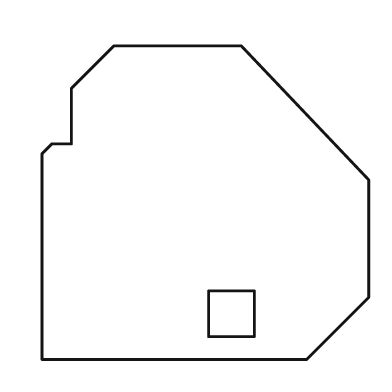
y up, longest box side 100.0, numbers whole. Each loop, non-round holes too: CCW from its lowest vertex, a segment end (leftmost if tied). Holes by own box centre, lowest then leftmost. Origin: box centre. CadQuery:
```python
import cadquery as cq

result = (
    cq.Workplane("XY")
    .moveTo(-50.0, -48.0)
    .lineTo(31.0, -48.0)
    .lineTo(50.0, -29.0)
    .lineTo(50.0, 7.0)
    .lineTo(11.0, 48.0)
    .lineTo(-28.0, 48.0)
    .lineTo(-41.0, 35.0)
    .lineTo(-41.0, 18.0)
    .lineTo(-47.0, 18.0)
    .lineTo(-50.0, 15.0)
    .close()
    .moveTo(1.0, -41.0)
    .lineTo(15.0, -41.0)
    .lineTo(15.0, -27.0)
    .lineTo(1.0, -27.0)
    .close()
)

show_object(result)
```